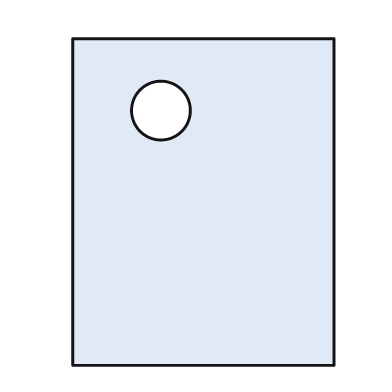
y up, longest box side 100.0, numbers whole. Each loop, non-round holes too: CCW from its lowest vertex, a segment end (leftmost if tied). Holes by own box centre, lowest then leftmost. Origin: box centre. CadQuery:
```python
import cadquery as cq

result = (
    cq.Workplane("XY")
    .moveTo(-40.0, -50.0)
    .lineTo(40.0, -50.0)
    .lineTo(40.0, 50.0)
    .lineTo(-40.0, 50.0)
    .close()
    .moveTo(-13.0, 28.0)
    .circle(9.0)
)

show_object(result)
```